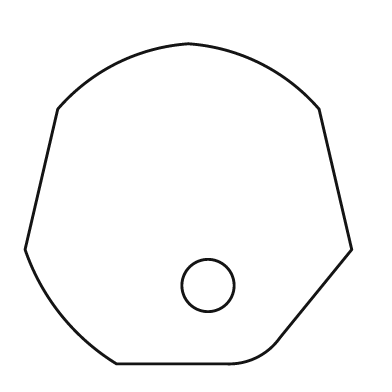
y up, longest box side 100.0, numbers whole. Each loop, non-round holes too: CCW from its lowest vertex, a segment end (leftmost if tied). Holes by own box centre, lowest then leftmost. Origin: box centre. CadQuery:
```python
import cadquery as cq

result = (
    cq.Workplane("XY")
    .moveTo(-22.0, -49.0)
    .lineTo(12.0, -49.0)
    .threePointArc((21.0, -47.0), (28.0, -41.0))
    .lineTo(50.0, -14.0)
    .lineTo(40.0, 29.0)
    .threePointArc((22.0, 43.0), (0.0, 49.0))
    .threePointArc((-22.0, 43.0), (-40.0, 29.0))
    .lineTo(-50.0, -14.0)
    .threePointArc((-39.0, -34.0), (-22.0, -49.0))
    .close()
    .moveTo(6.0, -25.0)
    .circle(8.0)
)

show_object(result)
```